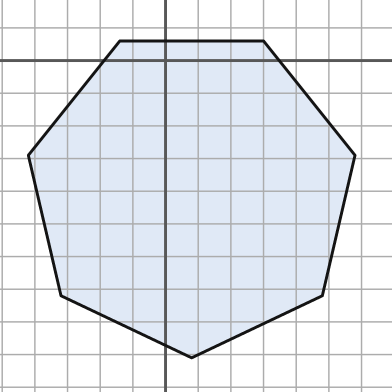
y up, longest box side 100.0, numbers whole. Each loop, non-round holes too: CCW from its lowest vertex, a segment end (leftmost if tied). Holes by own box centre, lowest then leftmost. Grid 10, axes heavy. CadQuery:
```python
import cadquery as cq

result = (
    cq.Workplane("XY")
    .moveTo(8.0, -91.0)
    .lineTo(48.0, -72.0)
    .lineTo(58.0, -29.0)
    .lineTo(30.0, 6.0)
    .lineTo(-14.0, 6.0)
    .lineTo(-42.0, -29.0)
    .lineTo(-32.0, -72.0)
    .close()
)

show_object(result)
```